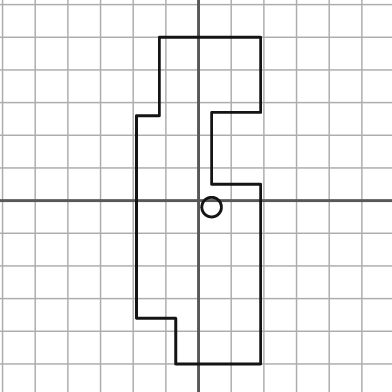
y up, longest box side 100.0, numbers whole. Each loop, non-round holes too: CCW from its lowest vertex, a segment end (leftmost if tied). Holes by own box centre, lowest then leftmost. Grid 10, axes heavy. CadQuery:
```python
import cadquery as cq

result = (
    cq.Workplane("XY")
    .moveTo(-7.0, -50.0)
    .lineTo(19.0, -50.0)
    .lineTo(19.0, 5.0)
    .lineTo(4.0, 5.0)
    .lineTo(4.0, 27.0)
    .lineTo(19.0, 27.0)
    .lineTo(19.0, 50.0)
    .lineTo(-12.0, 50.0)
    .lineTo(-12.0, 26.0)
    .lineTo(-19.0, 26.0)
    .lineTo(-19.0, -36.0)
    .lineTo(-7.0, -36.0)
    .close()
    .moveTo(4.0, -2.0)
    .circle(3.0)
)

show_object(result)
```